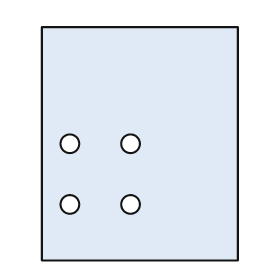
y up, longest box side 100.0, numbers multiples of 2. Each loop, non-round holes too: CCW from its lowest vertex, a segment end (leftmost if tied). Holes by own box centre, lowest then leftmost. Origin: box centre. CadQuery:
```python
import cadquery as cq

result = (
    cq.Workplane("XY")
    .moveTo(-42.0, -50.0)
    .lineTo(42.0, -50.0)
    .lineTo(42.0, 50.0)
    .lineTo(-42.0, 50.0)
    .close()
    .moveTo(-30.0, -26.0)
    .circle(4.0)
    .moveTo(-4.0, -26.0)
    .circle(4.0)
    .moveTo(-30.0, 0.0)
    .circle(4.0)
    .moveTo(-4.0, 0.0)
    .circle(4.0)
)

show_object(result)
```